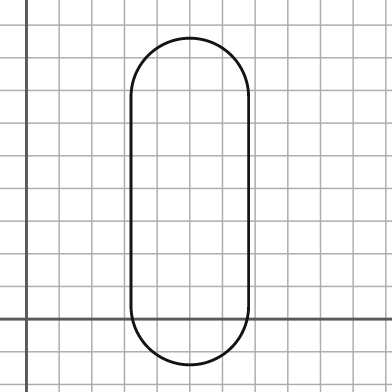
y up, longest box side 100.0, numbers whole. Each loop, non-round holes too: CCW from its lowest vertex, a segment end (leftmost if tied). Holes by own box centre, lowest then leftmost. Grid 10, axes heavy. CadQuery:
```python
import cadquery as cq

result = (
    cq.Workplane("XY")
    .moveTo(32.0, 4.0)
    .threePointArc((50.0, -14.0), (68.0, 4.0))
    .lineTo(68.0, 68.0)
    .threePointArc((50.0, 86.0), (32.0, 68.0))
    .close()
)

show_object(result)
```